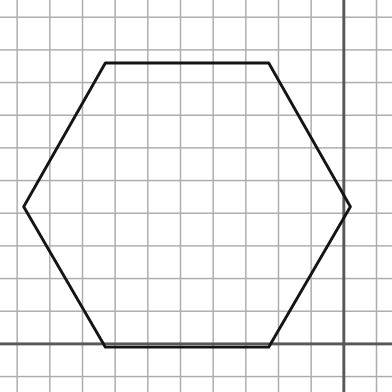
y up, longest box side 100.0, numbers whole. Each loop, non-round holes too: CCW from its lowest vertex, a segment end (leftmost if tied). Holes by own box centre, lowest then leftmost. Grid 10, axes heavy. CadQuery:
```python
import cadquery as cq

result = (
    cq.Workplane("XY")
    .moveTo(-73.0, -1.0)
    .lineTo(-23.0, -1.0)
    .lineTo(2.0, 42.0)
    .lineTo(-23.0, 86.0)
    .lineTo(-73.0, 86.0)
    .lineTo(-98.0, 42.0)
    .close()
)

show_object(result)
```